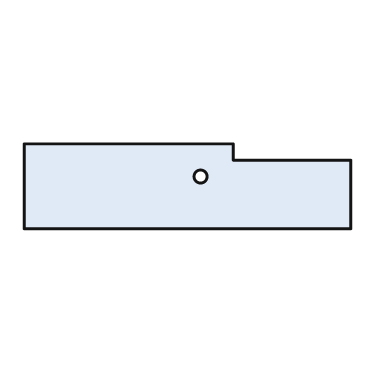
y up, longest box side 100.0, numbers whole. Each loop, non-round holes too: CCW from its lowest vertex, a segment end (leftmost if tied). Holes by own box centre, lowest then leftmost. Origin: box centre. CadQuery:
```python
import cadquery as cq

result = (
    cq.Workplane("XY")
    .moveTo(-50.0, -13.0)
    .lineTo(50.0, -13.0)
    .lineTo(50.0, 8.0)
    .lineTo(14.0, 8.0)
    .lineTo(14.0, 13.0)
    .lineTo(-50.0, 13.0)
    .close()
    .moveTo(4.0, 3.0)
    .circle(2.0)
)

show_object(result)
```